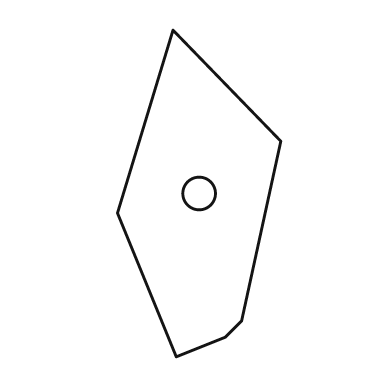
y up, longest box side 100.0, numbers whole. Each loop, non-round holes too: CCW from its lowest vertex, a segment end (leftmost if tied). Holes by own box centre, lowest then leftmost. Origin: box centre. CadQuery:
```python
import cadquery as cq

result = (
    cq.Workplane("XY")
    .moveTo(-7.0, -50.0)
    .lineTo(8.0, -44.0)
    .lineTo(13.0, -39.0)
    .lineTo(25.0, 16.0)
    .lineTo(-8.0, 50.0)
    .lineTo(-25.0, -6.0)
    .close()
    .moveTo(0.0, 0.0)
    .circle(5.0)
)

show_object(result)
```